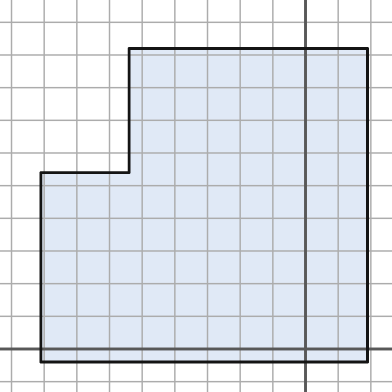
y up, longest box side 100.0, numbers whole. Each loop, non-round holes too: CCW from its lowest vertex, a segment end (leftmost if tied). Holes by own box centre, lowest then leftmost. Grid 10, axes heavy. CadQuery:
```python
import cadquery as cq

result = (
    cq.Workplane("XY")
    .moveTo(-81.0, -4.0)
    .lineTo(19.0, -4.0)
    .lineTo(19.0, 92.0)
    .lineTo(-54.0, 92.0)
    .lineTo(-54.0, 54.0)
    .lineTo(-81.0, 54.0)
    .close()
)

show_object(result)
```